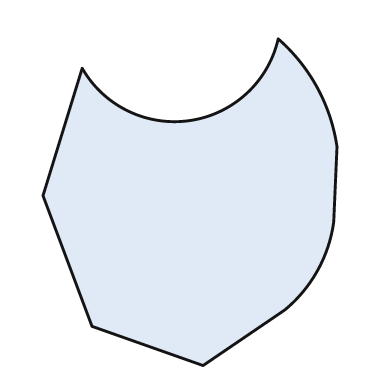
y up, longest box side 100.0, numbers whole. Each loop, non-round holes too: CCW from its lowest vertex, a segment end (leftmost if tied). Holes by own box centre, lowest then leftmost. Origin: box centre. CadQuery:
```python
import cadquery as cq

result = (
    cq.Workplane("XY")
    .moveTo(4.0, -50.0)
    .lineTo(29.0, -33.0)
    .threePointArc((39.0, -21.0), (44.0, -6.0))
    .lineTo(45.0, 17.0)
    .threePointArc((39.0, 35.0), (27.0, 50.0))
    .threePointArc((0.0, 25.0), (-33.0, 41.0))
    .lineTo(-45.0, 2.0)
    .lineTo(-30.0, -38.0)
    .close()
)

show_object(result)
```